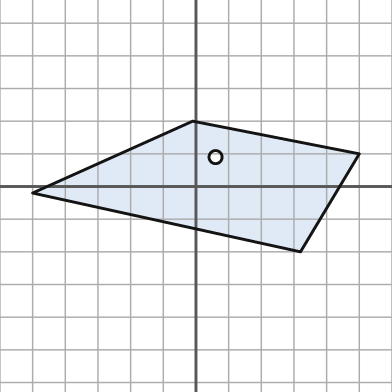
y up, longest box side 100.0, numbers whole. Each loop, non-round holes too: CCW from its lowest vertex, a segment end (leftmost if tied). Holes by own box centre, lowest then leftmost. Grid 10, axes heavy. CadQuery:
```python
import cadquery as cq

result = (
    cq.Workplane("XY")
    .moveTo(32.0, -20.0)
    .lineTo(50.0, 10.0)
    .lineTo(-1.0, 20.0)
    .lineTo(-50.0, -2.0)
    .close()
    .moveTo(6.0, 9.0)
    .circle(2.0)
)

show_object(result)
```